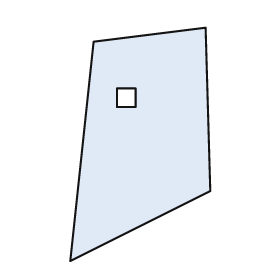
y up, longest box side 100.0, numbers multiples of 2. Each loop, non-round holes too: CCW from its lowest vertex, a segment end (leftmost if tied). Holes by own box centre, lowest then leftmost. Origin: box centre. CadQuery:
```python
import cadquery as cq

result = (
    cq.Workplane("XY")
    .moveTo(-30.0, -50.0)
    .lineTo(30.0, -20.0)
    .lineTo(28.0, 50.0)
    .lineTo(-20.0, 44.0)
    .close()
    .moveTo(-10.0, 16.0)
    .lineTo(-2.0, 16.0)
    .lineTo(-2.0, 24.0)
    .lineTo(-10.0, 24.0)
    .close()
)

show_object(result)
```